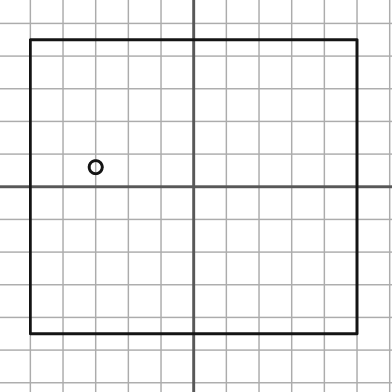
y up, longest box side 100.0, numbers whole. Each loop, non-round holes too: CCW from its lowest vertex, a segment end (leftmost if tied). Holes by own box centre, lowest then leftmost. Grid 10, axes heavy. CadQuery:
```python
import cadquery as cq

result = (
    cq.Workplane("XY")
    .moveTo(-50.0, -45.0)
    .lineTo(50.0, -45.0)
    .lineTo(50.0, 45.0)
    .lineTo(-50.0, 45.0)
    .close()
    .moveTo(-30.0, 6.0)
    .circle(2.0)
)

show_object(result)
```